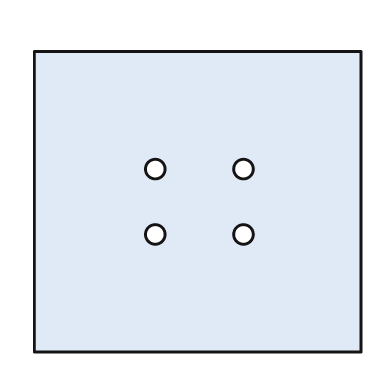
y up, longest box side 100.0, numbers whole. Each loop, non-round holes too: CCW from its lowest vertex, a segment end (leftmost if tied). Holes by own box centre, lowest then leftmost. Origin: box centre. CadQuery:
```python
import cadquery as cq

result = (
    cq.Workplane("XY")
    .moveTo(-50.0, -46.0)
    .lineTo(50.0, -46.0)
    .lineTo(50.0, 46.0)
    .lineTo(-50.0, 46.0)
    .close()
    .moveTo(-13.0, -10.0)
    .circle(3.0)
    .moveTo(14.0, -10.0)
    .circle(3.0)
    .moveTo(-13.0, 10.0)
    .circle(3.0)
    .moveTo(14.0, 10.0)
    .circle(3.0)
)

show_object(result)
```